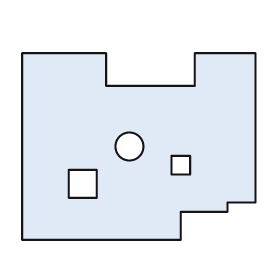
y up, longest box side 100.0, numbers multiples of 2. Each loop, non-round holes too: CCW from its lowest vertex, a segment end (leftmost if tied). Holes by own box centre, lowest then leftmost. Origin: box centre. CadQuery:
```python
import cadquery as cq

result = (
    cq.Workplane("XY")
    .moveTo(-50.0, -40.0)
    .lineTo(18.0, -40.0)
    .lineTo(18.0, -28.0)
    .lineTo(38.0, -28.0)
    .lineTo(38.0, -24.0)
    .lineTo(50.0, -24.0)
    .lineTo(50.0, 40.0)
    .lineTo(24.0, 40.0)
    .lineTo(24.0, 26.0)
    .lineTo(-14.0, 26.0)
    .lineTo(-14.0, 40.0)
    .lineTo(-50.0, 40.0)
    .close()
    .moveTo(-30.0, -22.0)
    .lineTo(-18.0, -22.0)
    .lineTo(-18.0, -10.0)
    .lineTo(-30.0, -10.0)
    .close()
    .moveTo(14.0, -12.0)
    .lineTo(22.0, -12.0)
    .lineTo(22.0, -4.0)
    .lineTo(14.0, -4.0)
    .close()
    .moveTo(-4.0, 0.0)
    .circle(6.0)
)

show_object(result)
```